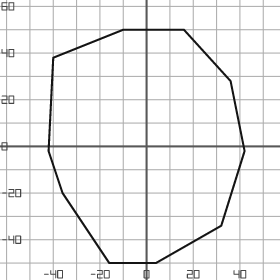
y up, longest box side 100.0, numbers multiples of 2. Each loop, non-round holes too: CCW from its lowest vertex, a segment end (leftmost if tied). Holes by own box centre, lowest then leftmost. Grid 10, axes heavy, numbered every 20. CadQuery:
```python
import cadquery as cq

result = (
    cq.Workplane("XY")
    .moveTo(-16.0, -50.0)
    .lineTo(4.0, -50.0)
    .lineTo(32.0, -34.0)
    .lineTo(42.0, -2.0)
    .lineTo(36.0, 28.0)
    .lineTo(16.0, 50.0)
    .lineTo(-10.0, 50.0)
    .lineTo(-40.0, 38.0)
    .lineTo(-42.0, -2.0)
    .lineTo(-36.0, -20.0)
    .close()
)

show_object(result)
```